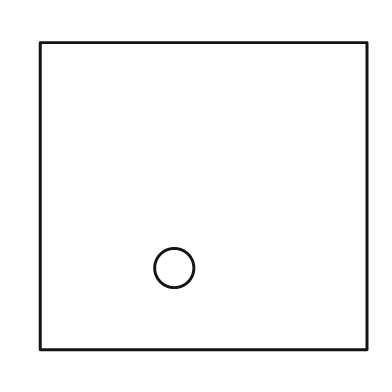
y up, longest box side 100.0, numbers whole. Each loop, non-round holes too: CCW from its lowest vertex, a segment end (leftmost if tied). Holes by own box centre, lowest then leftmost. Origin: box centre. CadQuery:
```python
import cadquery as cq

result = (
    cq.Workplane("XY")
    .moveTo(-50.0, -47.0)
    .lineTo(50.0, -47.0)
    .lineTo(50.0, 47.0)
    .lineTo(-50.0, 47.0)
    .close()
    .moveTo(-9.0, -22.0)
    .circle(6.0)
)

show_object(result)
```